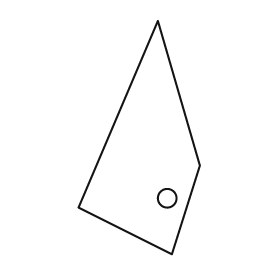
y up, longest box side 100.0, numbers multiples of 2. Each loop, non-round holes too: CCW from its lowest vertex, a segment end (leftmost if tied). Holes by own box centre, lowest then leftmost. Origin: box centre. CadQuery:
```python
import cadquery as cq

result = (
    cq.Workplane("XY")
    .moveTo(14.0, -50.0)
    .lineTo(26.0, -12.0)
    .lineTo(8.0, 50.0)
    .lineTo(-26.0, -30.0)
    .close()
    .moveTo(12.0, -26.0)
    .circle(4.0)
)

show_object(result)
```